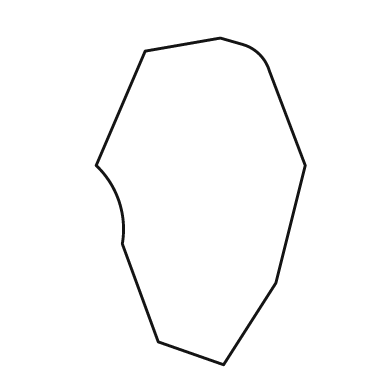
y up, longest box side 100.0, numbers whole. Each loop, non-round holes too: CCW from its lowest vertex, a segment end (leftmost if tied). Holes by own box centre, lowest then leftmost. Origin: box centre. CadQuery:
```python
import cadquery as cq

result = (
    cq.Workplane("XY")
    .moveTo(7.0, -50.0)
    .lineTo(23.0, -25.0)
    .lineTo(32.0, 11.0)
    .lineTo(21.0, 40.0)
    .threePointArc((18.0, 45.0), (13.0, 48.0))
    .lineTo(6.0, 50.0)
    .lineTo(-17.0, 46.0)
    .lineTo(-32.0, 11.0)
    .threePointArc((-25.0, 0.0), (-24.0, -13.0))
    .lineTo(-13.0, -43.0)
    .close()
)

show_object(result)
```